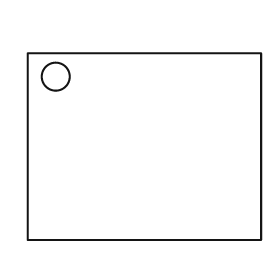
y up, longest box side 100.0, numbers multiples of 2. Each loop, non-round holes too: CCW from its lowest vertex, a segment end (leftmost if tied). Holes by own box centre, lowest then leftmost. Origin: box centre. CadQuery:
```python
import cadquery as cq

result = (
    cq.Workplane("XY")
    .moveTo(-50.0, -40.0)
    .lineTo(50.0, -40.0)
    .lineTo(50.0, 40.0)
    .lineTo(-50.0, 40.0)
    .close()
    .moveTo(-38.0, 30.0)
    .circle(6.0)
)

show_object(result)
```